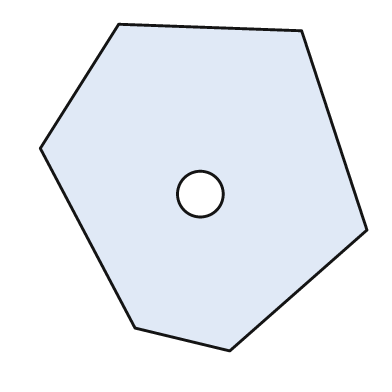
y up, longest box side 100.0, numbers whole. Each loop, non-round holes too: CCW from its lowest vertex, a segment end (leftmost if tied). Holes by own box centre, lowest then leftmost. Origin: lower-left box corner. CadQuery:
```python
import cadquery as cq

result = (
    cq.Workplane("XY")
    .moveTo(58.0, 0.0)
    .lineTo(100.0, 37.0)
    .lineTo(80.0, 98.0)
    .lineTo(24.0, 100.0)
    .lineTo(0.0, 62.0)
    .lineTo(29.0, 7.0)
    .close()
    .moveTo(49.0, 48.0)
    .circle(7.0)
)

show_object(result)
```